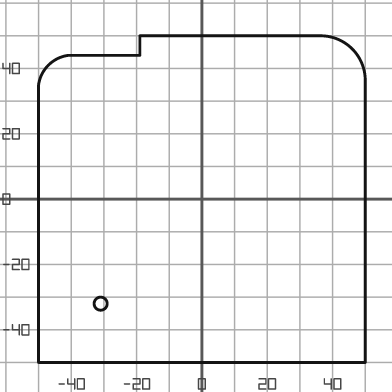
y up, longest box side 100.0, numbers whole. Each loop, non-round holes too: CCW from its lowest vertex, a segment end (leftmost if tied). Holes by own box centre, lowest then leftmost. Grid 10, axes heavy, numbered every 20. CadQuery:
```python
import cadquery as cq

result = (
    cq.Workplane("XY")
    .moveTo(-50.0, -50.0)
    .lineTo(50.0, -50.0)
    .lineTo(50.0, 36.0)
    .threePointArc((46.0, 46.0), (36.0, 50.0))
    .lineTo(-19.0, 50.0)
    .lineTo(-19.0, 44.0)
    .lineTo(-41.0, 44.0)
    .threePointArc((-47.0, 41.0), (-50.0, 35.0))
    .close()
    .moveTo(-31.0, -32.0)
    .circle(2.0)
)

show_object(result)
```